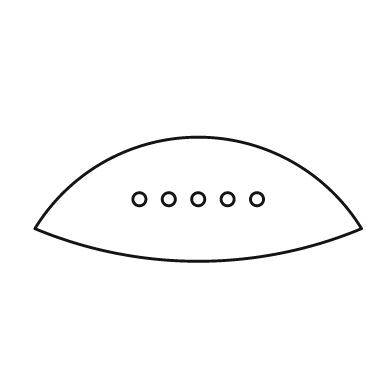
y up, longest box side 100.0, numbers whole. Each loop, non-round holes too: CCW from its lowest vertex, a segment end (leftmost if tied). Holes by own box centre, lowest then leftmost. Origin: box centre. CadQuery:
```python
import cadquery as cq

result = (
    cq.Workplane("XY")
    .moveTo(-50.0, -9.0)
    .threePointArc((0.0, -19.0), (50.0, -9.0))
    .threePointArc((0.0, 19.0), (-50.0, -9.0))
    .close()
    .moveTo(-18.0, 0.0)
    .circle(2.0)
    .moveTo(-9.0, 0.0)
    .circle(2.0)
    .moveTo(0.0, 0.0)
    .circle(2.0)
    .moveTo(9.0, 0.0)
    .circle(2.0)
    .moveTo(18.0, 0.0)
    .circle(2.0)
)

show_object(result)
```